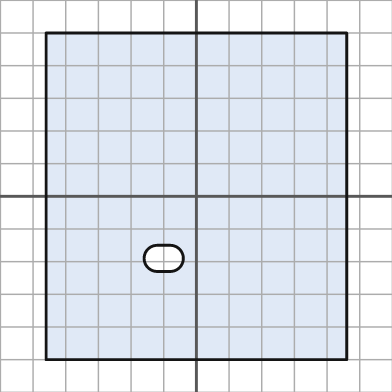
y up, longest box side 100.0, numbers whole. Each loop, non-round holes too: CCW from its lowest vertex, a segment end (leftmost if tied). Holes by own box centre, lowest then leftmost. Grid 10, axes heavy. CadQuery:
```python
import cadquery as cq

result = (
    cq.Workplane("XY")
    .moveTo(-46.0, -50.0)
    .lineTo(46.0, -50.0)
    .lineTo(46.0, 50.0)
    .lineTo(-46.0, 50.0)
    .close()
    .moveTo(-12.0, -23.0)
    .lineTo(-8.0, -23.0)
    .threePointArc((-4.0, -19.0), (-8.0, -15.0))
    .lineTo(-12.0, -15.0)
    .threePointArc((-16.0, -19.0), (-12.0, -23.0))
    .close()
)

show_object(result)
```